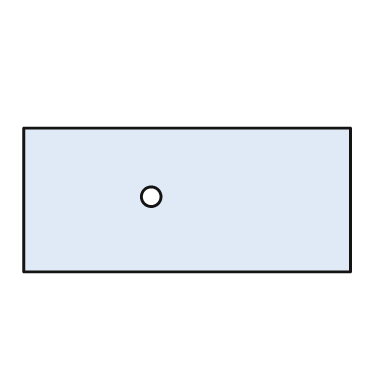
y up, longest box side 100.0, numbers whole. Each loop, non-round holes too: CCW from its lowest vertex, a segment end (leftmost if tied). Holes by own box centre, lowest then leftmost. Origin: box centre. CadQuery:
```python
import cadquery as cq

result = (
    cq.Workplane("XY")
    .moveTo(-50.0, -22.0)
    .lineTo(50.0, -22.0)
    .lineTo(50.0, 22.0)
    .lineTo(-50.0, 22.0)
    .close()
    .moveTo(-11.0, 1.0)
    .circle(3.0)
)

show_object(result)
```